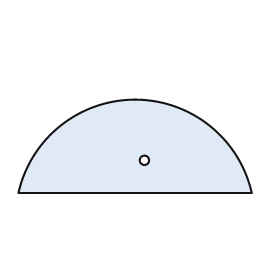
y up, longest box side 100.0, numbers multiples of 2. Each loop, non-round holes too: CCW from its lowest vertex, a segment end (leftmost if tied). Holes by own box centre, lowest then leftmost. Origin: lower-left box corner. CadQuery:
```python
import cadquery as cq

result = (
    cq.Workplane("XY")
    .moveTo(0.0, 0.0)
    .lineTo(100.0, 0.0)
    .threePointArc((50.0, 40.0), (0.0, 0.0))
    .close()
    .moveTo(54.0, 14.0)
    .circle(2.0)
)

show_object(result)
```